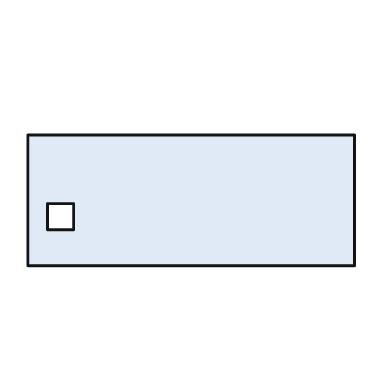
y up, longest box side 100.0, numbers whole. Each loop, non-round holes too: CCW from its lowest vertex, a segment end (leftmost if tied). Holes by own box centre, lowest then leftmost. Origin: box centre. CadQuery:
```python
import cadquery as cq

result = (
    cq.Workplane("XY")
    .moveTo(-50.0, -20.0)
    .lineTo(50.0, -20.0)
    .lineTo(50.0, 20.0)
    .lineTo(-50.0, 20.0)
    .close()
    .moveTo(-44.0, -9.0)
    .lineTo(-36.0, -9.0)
    .lineTo(-36.0, -1.0)
    .lineTo(-44.0, -1.0)
    .close()
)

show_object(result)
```